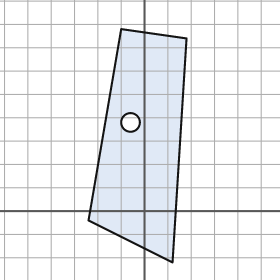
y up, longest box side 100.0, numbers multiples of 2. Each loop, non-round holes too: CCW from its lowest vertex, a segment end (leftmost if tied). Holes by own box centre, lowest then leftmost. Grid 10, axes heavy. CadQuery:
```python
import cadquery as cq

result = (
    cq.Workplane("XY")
    .moveTo(12.0, -22.0)
    .lineTo(18.0, 74.0)
    .lineTo(-10.0, 78.0)
    .lineTo(-24.0, -4.0)
    .close()
    .moveTo(-6.0, 38.0)
    .circle(4.0)
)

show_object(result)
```